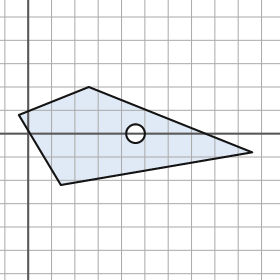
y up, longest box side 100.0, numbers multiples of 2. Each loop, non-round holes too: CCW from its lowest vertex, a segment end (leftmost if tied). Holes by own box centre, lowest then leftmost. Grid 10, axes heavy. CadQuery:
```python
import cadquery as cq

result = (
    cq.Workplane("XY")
    .moveTo(14.0, -22.0)
    .lineTo(96.0, -8.0)
    .lineTo(26.0, 20.0)
    .lineTo(-4.0, 8.0)
    .close()
    .moveTo(46.0, 0.0)
    .circle(4.0)
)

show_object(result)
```